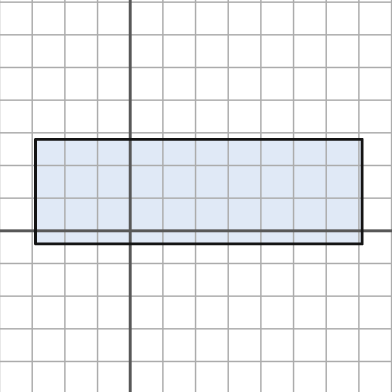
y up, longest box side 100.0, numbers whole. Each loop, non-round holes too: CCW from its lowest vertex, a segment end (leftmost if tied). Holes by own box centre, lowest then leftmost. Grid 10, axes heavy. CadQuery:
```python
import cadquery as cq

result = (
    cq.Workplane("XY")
    .moveTo(-29.0, -4.0)
    .lineTo(71.0, -4.0)
    .lineTo(71.0, 28.0)
    .lineTo(-29.0, 28.0)
    .close()
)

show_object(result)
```